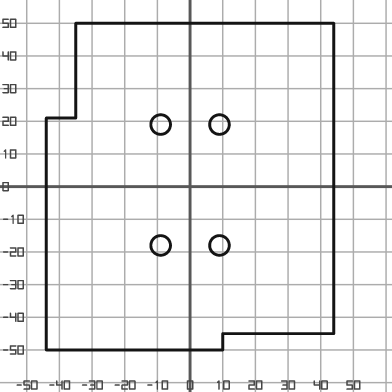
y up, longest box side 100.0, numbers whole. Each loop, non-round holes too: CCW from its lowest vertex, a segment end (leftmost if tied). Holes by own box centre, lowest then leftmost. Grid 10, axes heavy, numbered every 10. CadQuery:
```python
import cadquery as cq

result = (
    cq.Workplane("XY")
    .moveTo(-44.0, -50.0)
    .lineTo(10.0, -50.0)
    .lineTo(10.0, -45.0)
    .lineTo(44.0, -45.0)
    .lineTo(44.0, 50.0)
    .lineTo(-35.0, 50.0)
    .lineTo(-35.0, 21.0)
    .lineTo(-44.0, 21.0)
    .close()
    .moveTo(-9.0, -18.0)
    .circle(3.0)
    .moveTo(9.0, -18.0)
    .circle(3.0)
    .moveTo(-9.0, 19.0)
    .circle(3.0)
    .moveTo(9.0, 19.0)
    .circle(3.0)
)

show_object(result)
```